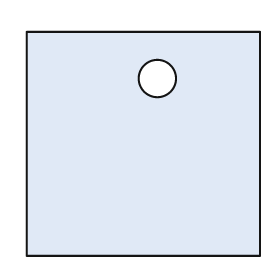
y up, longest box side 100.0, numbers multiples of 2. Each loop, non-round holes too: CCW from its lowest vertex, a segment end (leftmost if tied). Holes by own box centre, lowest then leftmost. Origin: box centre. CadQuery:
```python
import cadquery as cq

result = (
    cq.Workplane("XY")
    .moveTo(-50.0, -48.0)
    .lineTo(50.0, -48.0)
    .lineTo(50.0, 48.0)
    .lineTo(-50.0, 48.0)
    .close()
    .moveTo(6.0, 28.0)
    .circle(8.0)
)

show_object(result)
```